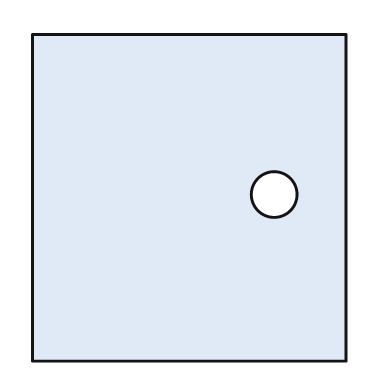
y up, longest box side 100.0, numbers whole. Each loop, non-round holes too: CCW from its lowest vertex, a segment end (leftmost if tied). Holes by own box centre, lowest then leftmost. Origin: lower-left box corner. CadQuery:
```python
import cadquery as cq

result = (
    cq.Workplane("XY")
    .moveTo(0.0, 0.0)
    .lineTo(96.0, 0.0)
    .lineTo(96.0, 100.0)
    .lineTo(0.0, 100.0)
    .close()
    .moveTo(74.0, 51.0)
    .circle(7.0)
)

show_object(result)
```